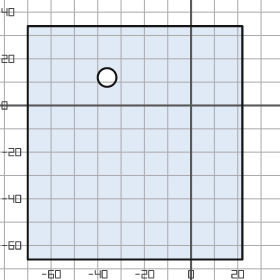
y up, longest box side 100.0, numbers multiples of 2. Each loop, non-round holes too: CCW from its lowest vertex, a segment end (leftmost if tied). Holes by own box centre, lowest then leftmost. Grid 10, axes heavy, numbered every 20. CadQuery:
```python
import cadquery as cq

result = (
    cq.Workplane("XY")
    .moveTo(-70.0, -66.0)
    .lineTo(22.0, -66.0)
    .lineTo(22.0, 34.0)
    .lineTo(-70.0, 34.0)
    .close()
    .moveTo(-36.0, 12.0)
    .circle(4.0)
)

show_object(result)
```